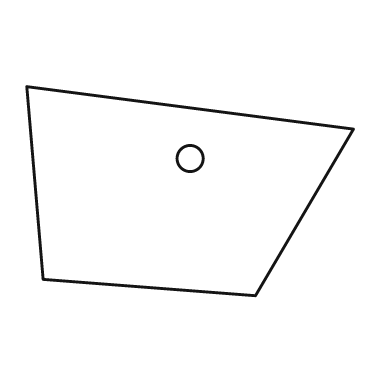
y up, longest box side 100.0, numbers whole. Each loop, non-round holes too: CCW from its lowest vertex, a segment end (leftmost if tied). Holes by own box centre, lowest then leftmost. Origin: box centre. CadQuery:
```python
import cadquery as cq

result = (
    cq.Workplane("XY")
    .moveTo(20.0, -32.0)
    .lineTo(50.0, 19.0)
    .lineTo(-50.0, 32.0)
    .lineTo(-45.0, -27.0)
    .close()
    .moveTo(0.0, 10.0)
    .circle(4.0)
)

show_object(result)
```